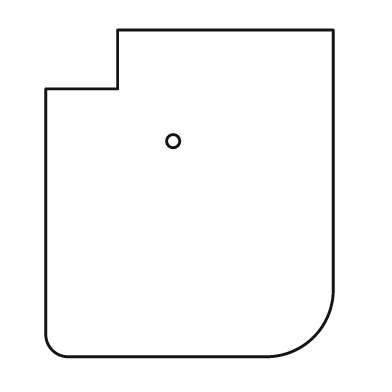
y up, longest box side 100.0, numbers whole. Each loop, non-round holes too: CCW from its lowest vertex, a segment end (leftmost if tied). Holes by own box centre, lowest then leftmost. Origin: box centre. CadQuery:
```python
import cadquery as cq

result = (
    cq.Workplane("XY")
    .moveTo(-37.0, -50.0)
    .lineTo(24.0, -50.0)
    .threePointArc((38.0, -44.0), (44.0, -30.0))
    .lineTo(44.0, 50.0)
    .lineTo(-22.0, 50.0)
    .lineTo(-22.0, 32.0)
    .lineTo(-44.0, 32.0)
    .lineTo(-44.0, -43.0)
    .threePointArc((-42.0, -48.0), (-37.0, -50.0))
    .close()
    .moveTo(-5.0, 16.0)
    .circle(2.0)
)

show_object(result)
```